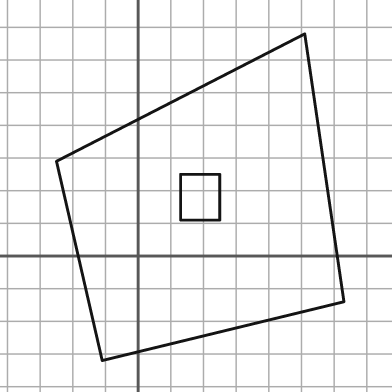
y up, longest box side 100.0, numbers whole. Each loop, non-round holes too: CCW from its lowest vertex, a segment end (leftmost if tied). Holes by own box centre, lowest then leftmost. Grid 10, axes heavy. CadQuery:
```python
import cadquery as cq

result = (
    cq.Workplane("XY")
    .moveTo(-11.0, -32.0)
    .lineTo(63.0, -14.0)
    .lineTo(51.0, 68.0)
    .lineTo(-25.0, 29.0)
    .close()
    .moveTo(13.0, 11.0)
    .lineTo(25.0, 11.0)
    .lineTo(25.0, 25.0)
    .lineTo(13.0, 25.0)
    .close()
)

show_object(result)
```